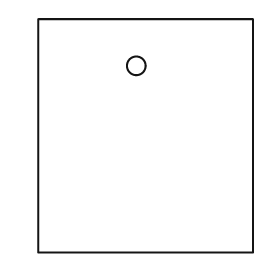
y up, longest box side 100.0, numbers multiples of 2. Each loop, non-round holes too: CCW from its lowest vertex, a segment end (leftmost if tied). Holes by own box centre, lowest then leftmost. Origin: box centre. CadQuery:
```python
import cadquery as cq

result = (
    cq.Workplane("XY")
    .moveTo(-46.0, -50.0)
    .lineTo(46.0, -50.0)
    .lineTo(46.0, 50.0)
    .lineTo(-46.0, 50.0)
    .close()
    .moveTo(-4.0, 30.0)
    .circle(4.0)
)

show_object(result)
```